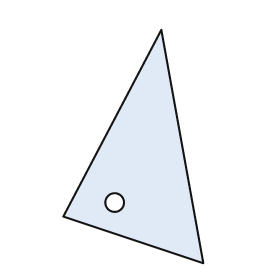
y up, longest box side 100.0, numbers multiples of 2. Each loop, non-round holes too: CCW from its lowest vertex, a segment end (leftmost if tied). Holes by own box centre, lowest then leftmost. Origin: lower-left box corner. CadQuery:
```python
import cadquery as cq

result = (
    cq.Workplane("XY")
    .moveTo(60.0, 0.0)
    .lineTo(42.0, 100.0)
    .lineTo(0.0, 20.0)
    .close()
    .moveTo(22.0, 26.0)
    .circle(4.0)
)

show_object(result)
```